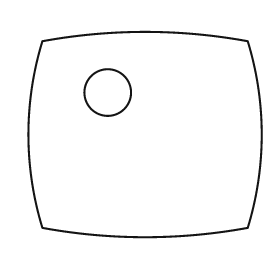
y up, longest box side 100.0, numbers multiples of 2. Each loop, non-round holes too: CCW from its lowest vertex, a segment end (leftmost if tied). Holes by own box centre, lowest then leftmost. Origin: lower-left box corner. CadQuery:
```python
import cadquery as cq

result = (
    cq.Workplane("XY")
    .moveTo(6.0, 4.0)
    .threePointArc((50.0, 0.0), (94.0, 4.0))
    .threePointArc((100.0, 44.0), (94.0, 84.0))
    .threePointArc((50.0, 88.0), (6.0, 84.0))
    .threePointArc((0.0, 44.0), (6.0, 4.0))
    .close()
    .moveTo(34.0, 62.0)
    .circle(10.0)
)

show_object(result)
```